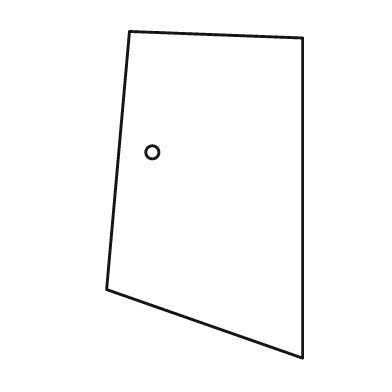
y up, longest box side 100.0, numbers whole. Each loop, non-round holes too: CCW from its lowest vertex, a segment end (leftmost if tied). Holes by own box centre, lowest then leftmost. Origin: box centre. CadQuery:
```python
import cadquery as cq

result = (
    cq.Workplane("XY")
    .moveTo(30.0, -50.0)
    .lineTo(30.0, 48.0)
    .lineTo(-23.0, 50.0)
    .lineTo(-30.0, -29.0)
    .close()
    .moveTo(-16.0, 13.0)
    .circle(2.0)
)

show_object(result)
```